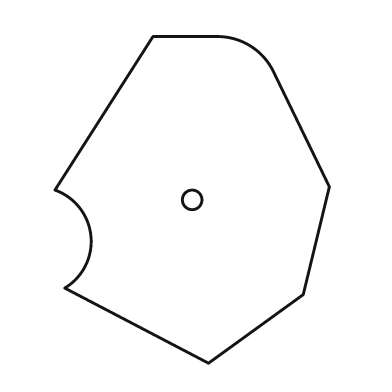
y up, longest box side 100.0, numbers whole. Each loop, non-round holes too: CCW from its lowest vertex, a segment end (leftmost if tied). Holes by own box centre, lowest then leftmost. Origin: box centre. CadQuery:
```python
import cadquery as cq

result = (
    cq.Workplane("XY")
    .moveTo(5.0, -50.0)
    .lineTo(34.0, -29.0)
    .lineTo(42.0, 4.0)
    .lineTo(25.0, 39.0)
    .threePointArc((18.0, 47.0), (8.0, 50.0))
    .lineTo(-12.0, 50.0)
    .lineTo(-42.0, 3.0)
    .threePointArc((-31.0, -11.0), (-39.0, -27.0))
    .close()
    .moveTo(0.0, 0.0)
    .circle(3.0)
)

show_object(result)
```